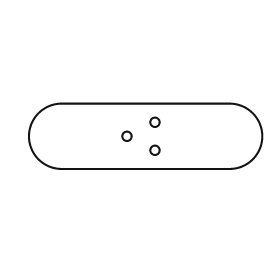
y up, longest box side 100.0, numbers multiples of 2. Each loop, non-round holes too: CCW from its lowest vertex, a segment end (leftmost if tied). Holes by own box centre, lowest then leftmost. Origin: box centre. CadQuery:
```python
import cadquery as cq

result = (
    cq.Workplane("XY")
    .moveTo(-36.0, -14.0)
    .lineTo(36.0, -14.0)
    .threePointArc((50.0, 0.0), (36.0, 14.0))
    .lineTo(-36.0, 14.0)
    .threePointArc((-50.0, 0.0), (-36.0, -14.0))
    .close()
    .moveTo(4.0, -6.0)
    .circle(2.0)
    .moveTo(-8.0, 0.0)
    .circle(2.0)
    .moveTo(4.0, 6.0)
    .circle(2.0)
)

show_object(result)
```